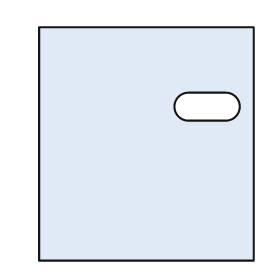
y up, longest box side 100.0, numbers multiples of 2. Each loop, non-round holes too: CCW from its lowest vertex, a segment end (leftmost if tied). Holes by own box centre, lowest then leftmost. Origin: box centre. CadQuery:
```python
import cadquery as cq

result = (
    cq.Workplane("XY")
    .moveTo(-46.0, -50.0)
    .lineTo(46.0, -50.0)
    .lineTo(46.0, 50.0)
    .lineTo(-46.0, 50.0)
    .close()
    .moveTo(18.0, 10.0)
    .lineTo(34.0, 10.0)
    .threePointArc((40.0, 16.0), (34.0, 22.0))
    .lineTo(18.0, 22.0)
    .threePointArc((12.0, 16.0), (18.0, 10.0))
    .close()
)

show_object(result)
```